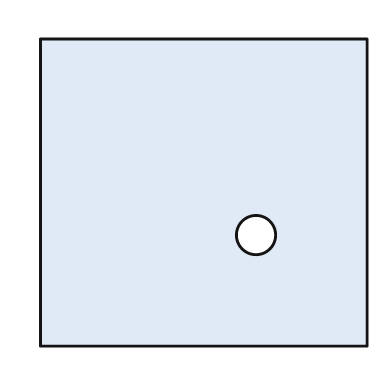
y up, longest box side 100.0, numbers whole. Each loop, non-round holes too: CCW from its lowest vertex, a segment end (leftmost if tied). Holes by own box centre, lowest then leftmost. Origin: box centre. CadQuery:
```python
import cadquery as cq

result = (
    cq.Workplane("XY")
    .moveTo(-50.0, -47.0)
    .lineTo(50.0, -47.0)
    .lineTo(50.0, 47.0)
    .lineTo(-50.0, 47.0)
    .close()
    .moveTo(16.0, -13.0)
    .circle(6.0)
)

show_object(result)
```